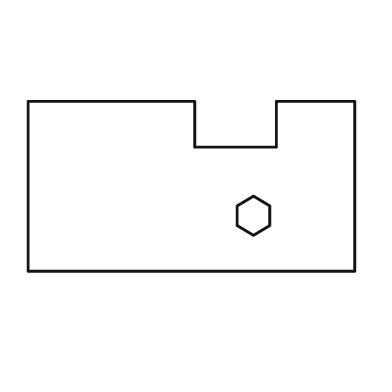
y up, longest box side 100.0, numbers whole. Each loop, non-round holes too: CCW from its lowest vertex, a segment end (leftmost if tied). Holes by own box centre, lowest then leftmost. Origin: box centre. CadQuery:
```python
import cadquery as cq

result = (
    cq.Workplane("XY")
    .moveTo(-50.0, -26.0)
    .lineTo(50.0, -26.0)
    .lineTo(50.0, 26.0)
    .lineTo(26.0, 26.0)
    .lineTo(26.0, 12.0)
    .lineTo(1.0, 12.0)
    .lineTo(1.0, 26.0)
    .lineTo(-50.0, 26.0)
    .close()
    .moveTo(19.0, -15.0)
    .lineTo(24.0, -12.0)
    .lineTo(24.0, -6.0)
    .lineTo(19.0, -3.0)
    .lineTo(14.0, -6.0)
    .lineTo(14.0, -12.0)
    .close()
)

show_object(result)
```